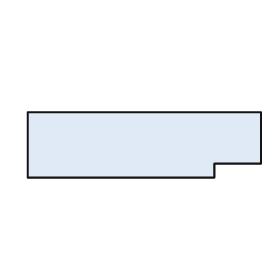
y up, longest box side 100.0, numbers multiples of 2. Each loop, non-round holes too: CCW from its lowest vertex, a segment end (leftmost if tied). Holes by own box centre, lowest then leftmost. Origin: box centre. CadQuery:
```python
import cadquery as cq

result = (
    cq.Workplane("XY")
    .moveTo(-50.0, -14.0)
    .lineTo(30.0, -14.0)
    .lineTo(30.0, -8.0)
    .lineTo(50.0, -8.0)
    .lineTo(50.0, 14.0)
    .lineTo(-50.0, 14.0)
    .close()
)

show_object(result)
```